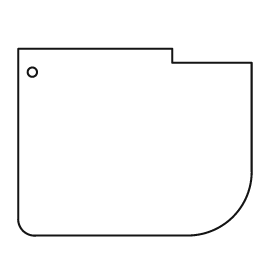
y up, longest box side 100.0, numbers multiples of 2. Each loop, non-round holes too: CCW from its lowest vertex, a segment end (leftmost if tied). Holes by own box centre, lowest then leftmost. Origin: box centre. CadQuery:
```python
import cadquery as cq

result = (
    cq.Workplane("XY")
    .moveTo(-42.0, -40.0)
    .lineTo(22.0, -40.0)
    .threePointArc((42.0, -32.0), (50.0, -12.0))
    .lineTo(50.0, 34.0)
    .lineTo(16.0, 34.0)
    .lineTo(16.0, 40.0)
    .lineTo(-50.0, 40.0)
    .lineTo(-50.0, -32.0)
    .threePointArc((-48.0, -38.0), (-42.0, -40.0))
    .close()
    .moveTo(-44.0, 30.0)
    .circle(2.0)
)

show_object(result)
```